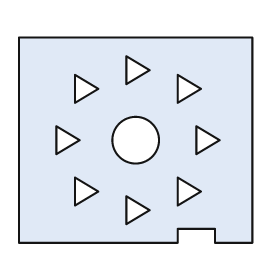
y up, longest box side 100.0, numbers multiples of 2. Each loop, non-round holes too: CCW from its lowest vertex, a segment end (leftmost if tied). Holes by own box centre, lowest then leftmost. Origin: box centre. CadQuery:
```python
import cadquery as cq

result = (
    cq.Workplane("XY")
    .moveTo(-50.0, -44.0)
    .lineTo(18.0, -44.0)
    .lineTo(18.0, -38.0)
    .lineTo(34.0, -38.0)
    .lineTo(34.0, -44.0)
    .lineTo(50.0, -44.0)
    .lineTo(50.0, 44.0)
    .lineTo(-50.0, 44.0)
    .close()
    .moveTo(-4.0, -36.0)
    .lineTo(6.0, -30.0)
    .lineTo(-4.0, -24.0)
    .close()
    .moveTo(-26.0, -28.0)
    .lineTo(-16.0, -22.0)
    .lineTo(-26.0, -16.0)
    .close()
    .moveTo(18.0, -28.0)
    .lineTo(28.0, -22.0)
    .lineTo(18.0, -16.0)
    .close()
    .moveTo(-34.0, -6.0)
    .lineTo(-24.0, 0.0)
    .lineTo(-34.0, 6.0)
    .close()
    .moveTo(0.0, 0.0)
    .circle(10.0)
    .moveTo(26.0, -6.0)
    .lineTo(36.0, 0.0)
    .lineTo(26.0, 6.0)
    .close()
    .moveTo(-26.0, 16.0)
    .lineTo(-16.0, 22.0)
    .lineTo(-26.0, 28.0)
    .close()
    .moveTo(18.0, 16.0)
    .lineTo(28.0, 22.0)
    .lineTo(18.0, 28.0)
    .close()
    .moveTo(-4.0, 24.0)
    .lineTo(6.0, 30.0)
    .lineTo(-4.0, 36.0)
    .close()
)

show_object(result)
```